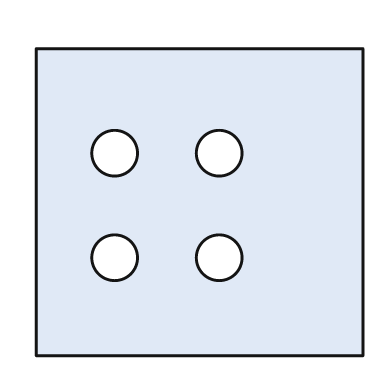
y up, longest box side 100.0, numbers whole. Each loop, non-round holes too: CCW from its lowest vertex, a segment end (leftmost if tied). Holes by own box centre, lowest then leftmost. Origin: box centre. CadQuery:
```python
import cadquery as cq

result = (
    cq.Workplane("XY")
    .moveTo(-50.0, -47.0)
    .lineTo(50.0, -47.0)
    .lineTo(50.0, 47.0)
    .lineTo(-50.0, 47.0)
    .close()
    .moveTo(-26.0, -17.0)
    .circle(7.0)
    .moveTo(6.0, -17.0)
    .circle(7.0)
    .moveTo(-26.0, 15.0)
    .circle(7.0)
    .moveTo(6.0, 15.0)
    .circle(7.0)
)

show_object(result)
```